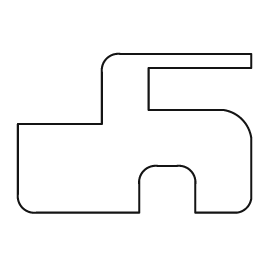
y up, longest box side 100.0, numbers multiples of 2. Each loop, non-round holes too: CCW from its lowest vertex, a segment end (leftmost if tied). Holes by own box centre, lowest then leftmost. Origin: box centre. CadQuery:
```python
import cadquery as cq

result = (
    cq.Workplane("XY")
    .moveTo(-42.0, -34.0)
    .lineTo(2.0, -34.0)
    .lineTo(2.0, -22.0)
    .threePointArc((4.0, -16.0), (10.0, -14.0))
    .lineTo(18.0, -14.0)
    .threePointArc((24.0, -16.0), (26.0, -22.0))
    .lineTo(26.0, -34.0)
    .lineTo(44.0, -34.0)
    .threePointArc((48.0, -32.0), (50.0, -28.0))
    .lineTo(50.0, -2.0)
    .threePointArc((46.0, 6.0), (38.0, 10.0))
    .lineTo(6.0, 10.0)
    .lineTo(6.0, 28.0)
    .lineTo(50.0, 28.0)
    .lineTo(50.0, 34.0)
    .lineTo(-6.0, 34.0)
    .threePointArc((-12.0, 32.0), (-14.0, 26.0))
    .lineTo(-14.0, 4.0)
    .lineTo(-50.0, 4.0)
    .lineTo(-50.0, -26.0)
    .threePointArc((-48.0, -32.0), (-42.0, -34.0))
    .close()
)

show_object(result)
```